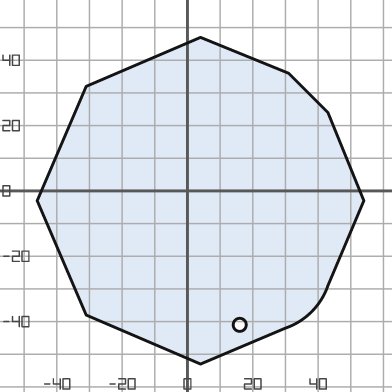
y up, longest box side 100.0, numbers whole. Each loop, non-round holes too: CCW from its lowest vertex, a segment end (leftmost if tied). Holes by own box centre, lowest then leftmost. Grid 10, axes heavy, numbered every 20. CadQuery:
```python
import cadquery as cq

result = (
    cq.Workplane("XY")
    .moveTo(4.0, -53.0)
    .lineTo(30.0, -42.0)
    .threePointArc((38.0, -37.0), (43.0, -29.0))
    .lineTo(54.0, -3.0)
    .lineTo(43.0, 24.0)
    .lineTo(31.0, 36.0)
    .lineTo(4.0, 47.0)
    .lineTo(-31.0, 32.0)
    .lineTo(-46.0, -3.0)
    .lineTo(-31.0, -38.0)
    .close()
    .moveTo(16.0, -41.0)
    .circle(2.0)
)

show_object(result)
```